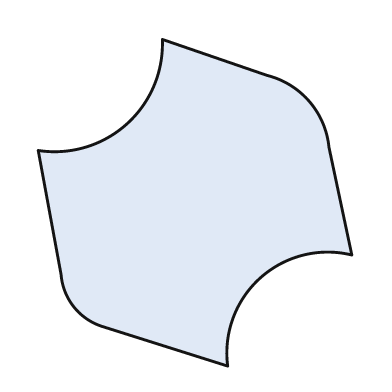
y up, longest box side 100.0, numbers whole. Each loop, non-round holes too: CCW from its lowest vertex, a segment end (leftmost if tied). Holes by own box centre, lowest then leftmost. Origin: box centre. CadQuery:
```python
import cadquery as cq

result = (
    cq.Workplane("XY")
    .moveTo(10.0, -50.0)
    .threePointArc((20.0, -23.0), (48.0, -16.0))
    .lineTo(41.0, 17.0)
    .threePointArc((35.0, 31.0), (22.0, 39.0))
    .lineTo(-10.0, 50.0)
    .threePointArc((-21.0, 24.0), (-48.0, 16.0))
    .lineTo(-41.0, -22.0)
    .threePointArc((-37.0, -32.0), (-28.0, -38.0))
    .close()
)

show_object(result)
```